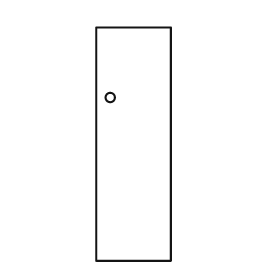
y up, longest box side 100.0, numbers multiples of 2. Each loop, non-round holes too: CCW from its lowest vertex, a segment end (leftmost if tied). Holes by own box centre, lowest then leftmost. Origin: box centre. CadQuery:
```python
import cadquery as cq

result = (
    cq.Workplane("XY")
    .moveTo(-16.0, -50.0)
    .lineTo(16.0, -50.0)
    .lineTo(16.0, 50.0)
    .lineTo(-16.0, 50.0)
    .close()
    .moveTo(-10.0, 20.0)
    .circle(2.0)
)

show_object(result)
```